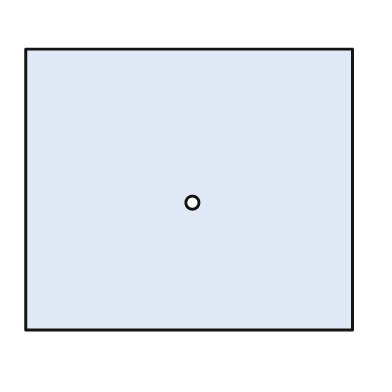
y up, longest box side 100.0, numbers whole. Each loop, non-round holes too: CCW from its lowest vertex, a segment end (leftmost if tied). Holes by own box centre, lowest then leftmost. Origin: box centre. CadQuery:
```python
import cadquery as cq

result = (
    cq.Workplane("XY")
    .moveTo(-50.0, -43.0)
    .lineTo(50.0, -43.0)
    .lineTo(50.0, 43.0)
    .lineTo(-50.0, 43.0)
    .close()
    .moveTo(1.0, -4.0)
    .circle(2.0)
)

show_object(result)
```